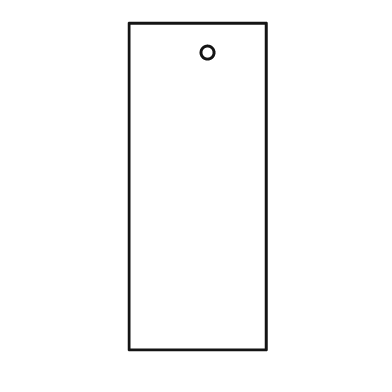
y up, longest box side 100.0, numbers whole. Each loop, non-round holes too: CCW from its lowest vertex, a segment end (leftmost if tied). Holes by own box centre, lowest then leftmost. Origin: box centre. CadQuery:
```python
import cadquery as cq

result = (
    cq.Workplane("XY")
    .moveTo(-21.0, -50.0)
    .lineTo(21.0, -50.0)
    .lineTo(21.0, 50.0)
    .lineTo(-21.0, 50.0)
    .close()
    .moveTo(3.0, 41.0)
    .circle(2.0)
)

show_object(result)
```